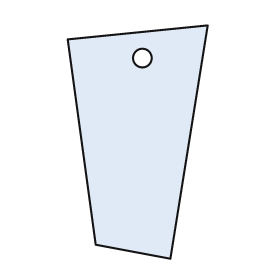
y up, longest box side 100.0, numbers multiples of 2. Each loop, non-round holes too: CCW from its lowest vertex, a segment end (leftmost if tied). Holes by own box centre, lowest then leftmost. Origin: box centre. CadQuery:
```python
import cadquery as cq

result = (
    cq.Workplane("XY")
    .moveTo(14.0, -50.0)
    .lineTo(30.0, 50.0)
    .lineTo(-30.0, 44.0)
    .lineTo(-18.0, -44.0)
    .close()
    .moveTo(2.0, 36.0)
    .circle(4.0)
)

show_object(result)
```